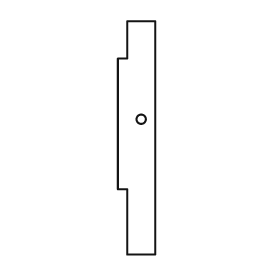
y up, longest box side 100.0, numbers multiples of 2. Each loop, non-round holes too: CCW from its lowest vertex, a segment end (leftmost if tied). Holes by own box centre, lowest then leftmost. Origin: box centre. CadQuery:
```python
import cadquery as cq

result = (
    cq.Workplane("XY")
    .moveTo(-4.0, -50.0)
    .lineTo(8.0, -50.0)
    .lineTo(8.0, 50.0)
    .lineTo(-4.0, 50.0)
    .lineTo(-4.0, 34.0)
    .lineTo(-8.0, 34.0)
    .lineTo(-8.0, -22.0)
    .lineTo(-4.0, -22.0)
    .close()
    .moveTo(2.0, 8.0)
    .circle(2.0)
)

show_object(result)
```